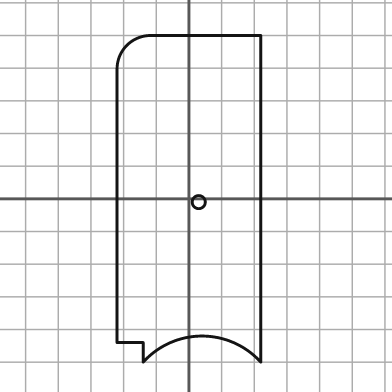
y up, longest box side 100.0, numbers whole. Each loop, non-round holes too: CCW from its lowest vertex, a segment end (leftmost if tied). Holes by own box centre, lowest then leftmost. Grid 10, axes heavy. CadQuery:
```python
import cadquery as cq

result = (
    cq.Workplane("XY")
    .moveTo(-14.0, -50.0)
    .threePointArc((4.0, -42.0), (22.0, -50.0))
    .lineTo(22.0, 50.0)
    .lineTo(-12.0, 50.0)
    .threePointArc((-19.0, 47.0), (-22.0, 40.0))
    .lineTo(-22.0, -44.0)
    .lineTo(-14.0, -44.0)
    .close()
    .moveTo(3.0, -1.0)
    .circle(2.0)
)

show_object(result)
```